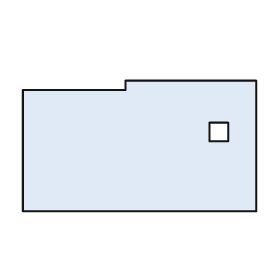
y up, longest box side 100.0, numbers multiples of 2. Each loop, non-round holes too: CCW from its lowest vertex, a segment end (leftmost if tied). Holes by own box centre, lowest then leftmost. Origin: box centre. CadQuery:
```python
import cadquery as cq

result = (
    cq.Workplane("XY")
    .moveTo(-50.0, -28.0)
    .lineTo(50.0, -28.0)
    .lineTo(50.0, 28.0)
    .lineTo(-6.0, 28.0)
    .lineTo(-6.0, 24.0)
    .lineTo(-50.0, 24.0)
    .close()
    .moveTo(30.0, 2.0)
    .lineTo(38.0, 2.0)
    .lineTo(38.0, 10.0)
    .lineTo(30.0, 10.0)
    .close()
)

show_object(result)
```